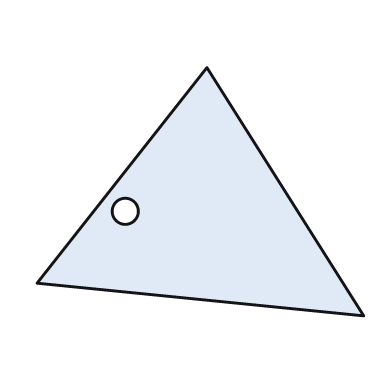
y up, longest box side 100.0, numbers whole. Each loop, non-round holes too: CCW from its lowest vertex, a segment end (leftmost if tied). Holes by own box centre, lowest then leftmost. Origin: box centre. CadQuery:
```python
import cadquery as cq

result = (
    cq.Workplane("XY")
    .moveTo(50.0, -38.0)
    .lineTo(2.0, 38.0)
    .lineTo(-50.0, -28.0)
    .close()
    .moveTo(-23.0, -6.0)
    .circle(4.0)
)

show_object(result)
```